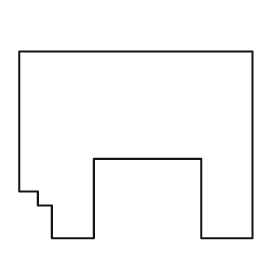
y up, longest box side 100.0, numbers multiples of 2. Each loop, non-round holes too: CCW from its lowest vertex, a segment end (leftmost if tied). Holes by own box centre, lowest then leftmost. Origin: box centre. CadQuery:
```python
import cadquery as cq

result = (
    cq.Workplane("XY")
    .moveTo(-36.0, -40.0)
    .lineTo(-18.0, -40.0)
    .lineTo(-18.0, -6.0)
    .lineTo(28.0, -6.0)
    .lineTo(28.0, -40.0)
    .lineTo(50.0, -40.0)
    .lineTo(50.0, 40.0)
    .lineTo(-50.0, 40.0)
    .lineTo(-50.0, -20.0)
    .lineTo(-42.0, -20.0)
    .lineTo(-42.0, -26.0)
    .lineTo(-36.0, -26.0)
    .close()
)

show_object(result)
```